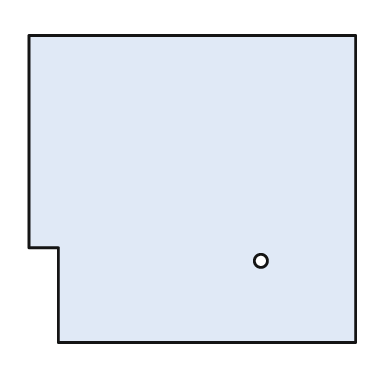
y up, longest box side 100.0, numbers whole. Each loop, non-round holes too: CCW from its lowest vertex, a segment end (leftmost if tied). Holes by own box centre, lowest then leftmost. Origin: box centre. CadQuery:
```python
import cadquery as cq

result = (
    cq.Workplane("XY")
    .moveTo(-41.0, -47.0)
    .lineTo(50.0, -47.0)
    .lineTo(50.0, 47.0)
    .lineTo(-50.0, 47.0)
    .lineTo(-50.0, -18.0)
    .lineTo(-41.0, -18.0)
    .close()
    .moveTo(21.0, -22.0)
    .circle(2.0)
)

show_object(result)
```